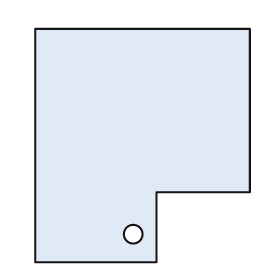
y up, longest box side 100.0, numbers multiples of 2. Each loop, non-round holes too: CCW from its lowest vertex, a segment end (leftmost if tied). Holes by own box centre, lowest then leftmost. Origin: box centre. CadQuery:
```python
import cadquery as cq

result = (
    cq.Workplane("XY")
    .moveTo(-46.0, -50.0)
    .lineTo(6.0, -50.0)
    .lineTo(6.0, -20.0)
    .lineTo(46.0, -20.0)
    .lineTo(46.0, 50.0)
    .lineTo(-46.0, 50.0)
    .close()
    .moveTo(-4.0, -38.0)
    .circle(4.0)
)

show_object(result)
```